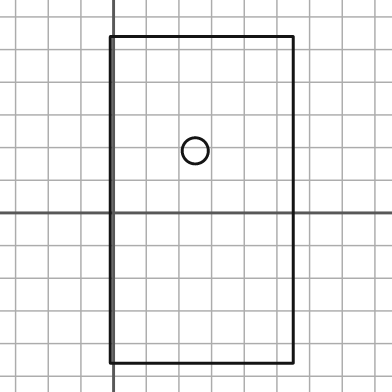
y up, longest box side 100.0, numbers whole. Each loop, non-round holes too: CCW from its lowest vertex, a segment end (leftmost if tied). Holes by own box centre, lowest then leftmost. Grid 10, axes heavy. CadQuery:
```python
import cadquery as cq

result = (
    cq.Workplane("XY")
    .moveTo(-1.0, -46.0)
    .lineTo(55.0, -46.0)
    .lineTo(55.0, 54.0)
    .lineTo(-1.0, 54.0)
    .close()
    .moveTo(25.0, 19.0)
    .circle(4.0)
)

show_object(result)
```